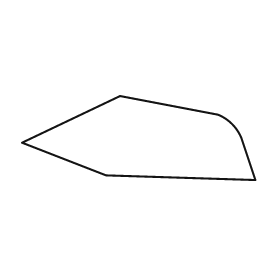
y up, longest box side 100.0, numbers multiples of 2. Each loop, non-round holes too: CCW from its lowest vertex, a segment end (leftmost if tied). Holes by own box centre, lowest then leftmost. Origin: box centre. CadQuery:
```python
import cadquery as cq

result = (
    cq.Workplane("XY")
    .moveTo(50.0, -18.0)
    .lineTo(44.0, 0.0)
    .threePointArc((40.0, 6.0), (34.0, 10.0))
    .lineTo(-8.0, 18.0)
    .lineTo(-50.0, -2.0)
    .lineTo(-14.0, -16.0)
    .close()
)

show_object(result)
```